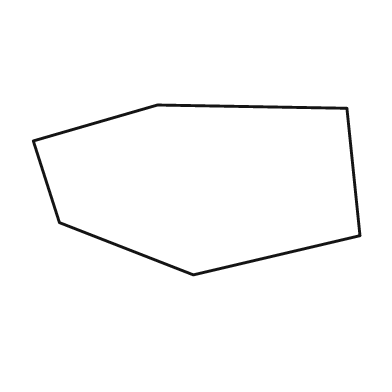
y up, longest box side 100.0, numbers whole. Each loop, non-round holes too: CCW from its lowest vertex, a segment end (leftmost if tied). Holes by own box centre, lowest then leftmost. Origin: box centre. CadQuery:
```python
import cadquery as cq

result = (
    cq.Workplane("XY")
    .moveTo(-1.0, -26.0)
    .lineTo(50.0, -14.0)
    .lineTo(46.0, 25.0)
    .lineTo(-12.0, 26.0)
    .lineTo(-50.0, 15.0)
    .lineTo(-42.0, -10.0)
    .close()
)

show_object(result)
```